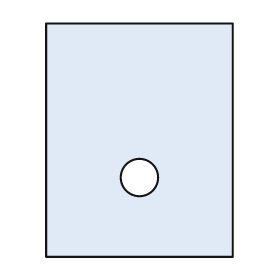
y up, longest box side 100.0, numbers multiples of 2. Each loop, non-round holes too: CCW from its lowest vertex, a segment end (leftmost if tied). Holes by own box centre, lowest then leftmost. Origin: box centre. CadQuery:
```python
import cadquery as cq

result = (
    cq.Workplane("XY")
    .moveTo(-40.0, -50.0)
    .lineTo(40.0, -50.0)
    .lineTo(40.0, 50.0)
    .lineTo(-40.0, 50.0)
    .close()
    .moveTo(0.0, -16.0)
    .circle(8.0)
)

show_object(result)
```